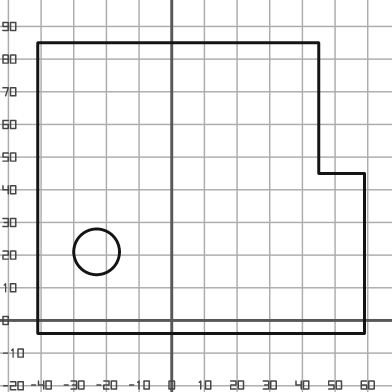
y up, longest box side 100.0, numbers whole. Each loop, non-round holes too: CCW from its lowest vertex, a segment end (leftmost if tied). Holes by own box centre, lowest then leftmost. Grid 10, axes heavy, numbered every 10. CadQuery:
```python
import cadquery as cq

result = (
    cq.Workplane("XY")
    .moveTo(-41.0, -4.0)
    .lineTo(59.0, -4.0)
    .lineTo(59.0, 45.0)
    .lineTo(45.0, 45.0)
    .lineTo(45.0, 85.0)
    .lineTo(-41.0, 85.0)
    .close()
    .moveTo(-23.0, 21.0)
    .circle(7.0)
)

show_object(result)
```